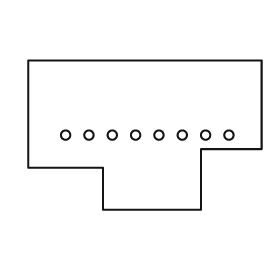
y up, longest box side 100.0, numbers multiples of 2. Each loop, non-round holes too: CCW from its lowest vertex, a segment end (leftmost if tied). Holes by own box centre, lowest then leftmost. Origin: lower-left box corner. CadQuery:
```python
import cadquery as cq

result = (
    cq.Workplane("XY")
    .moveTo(32.0, 0.0)
    .lineTo(74.0, 0.0)
    .lineTo(74.0, 26.0)
    .lineTo(100.0, 26.0)
    .lineTo(100.0, 64.0)
    .lineTo(0.0, 64.0)
    .lineTo(0.0, 18.0)
    .lineTo(32.0, 18.0)
    .close()
    .moveTo(16.0, 32.0)
    .circle(2.0)
    .moveTo(26.0, 32.0)
    .circle(2.0)
    .moveTo(36.0, 32.0)
    .circle(2.0)
    .moveTo(46.0, 32.0)
    .circle(2.0)
    .moveTo(56.0, 32.0)
    .circle(2.0)
    .moveTo(66.0, 32.0)
    .circle(2.0)
    .moveTo(76.0, 32.0)
    .circle(2.0)
    .moveTo(86.0, 32.0)
    .circle(2.0)
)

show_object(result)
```